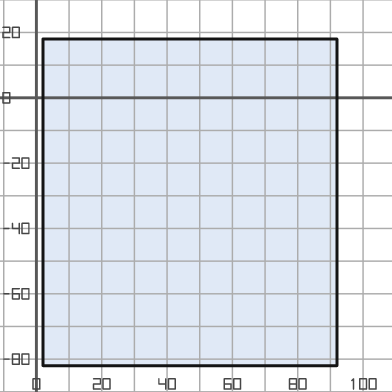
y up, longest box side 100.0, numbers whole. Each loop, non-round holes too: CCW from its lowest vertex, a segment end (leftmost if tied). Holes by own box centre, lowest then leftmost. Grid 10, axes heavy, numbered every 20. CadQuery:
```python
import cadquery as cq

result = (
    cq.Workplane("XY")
    .moveTo(2.0, -82.0)
    .lineTo(92.0, -82.0)
    .lineTo(92.0, 18.0)
    .lineTo(2.0, 18.0)
    .close()
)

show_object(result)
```